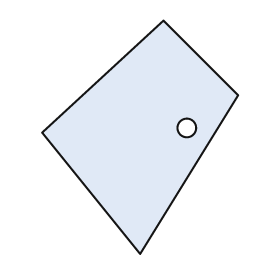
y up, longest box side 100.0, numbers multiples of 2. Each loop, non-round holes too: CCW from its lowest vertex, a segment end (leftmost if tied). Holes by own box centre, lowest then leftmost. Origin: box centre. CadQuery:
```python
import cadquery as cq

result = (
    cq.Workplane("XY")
    .moveTo(0.0, -50.0)
    .lineTo(42.0, 18.0)
    .lineTo(10.0, 50.0)
    .lineTo(-42.0, 2.0)
    .close()
    .moveTo(20.0, 4.0)
    .circle(4.0)
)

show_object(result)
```